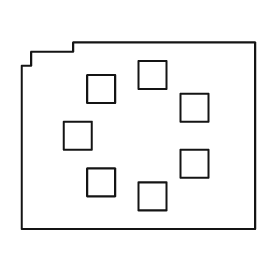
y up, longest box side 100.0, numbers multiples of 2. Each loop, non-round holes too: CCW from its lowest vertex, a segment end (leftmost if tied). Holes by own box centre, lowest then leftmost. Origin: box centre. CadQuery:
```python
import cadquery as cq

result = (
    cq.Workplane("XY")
    .moveTo(-50.0, -40.0)
    .lineTo(50.0, -40.0)
    .lineTo(50.0, 40.0)
    .lineTo(-28.0, 40.0)
    .lineTo(-28.0, 36.0)
    .lineTo(-46.0, 36.0)
    .lineTo(-46.0, 30.0)
    .lineTo(-50.0, 30.0)
    .close()
    .moveTo(0.0, -32.0)
    .lineTo(12.0, -32.0)
    .lineTo(12.0, -20.0)
    .lineTo(0.0, -20.0)
    .close()
    .moveTo(-22.0, -26.0)
    .lineTo(-10.0, -26.0)
    .lineTo(-10.0, -14.0)
    .lineTo(-22.0, -14.0)
    .close()
    .moveTo(18.0, -18.0)
    .lineTo(30.0, -18.0)
    .lineTo(30.0, -6.0)
    .lineTo(18.0, -6.0)
    .close()
    .moveTo(-32.0, -6.0)
    .lineTo(-20.0, -6.0)
    .lineTo(-20.0, 6.0)
    .lineTo(-32.0, 6.0)
    .close()
    .moveTo(18.0, 6.0)
    .lineTo(30.0, 6.0)
    .lineTo(30.0, 18.0)
    .lineTo(18.0, 18.0)
    .close()
    .moveTo(-22.0, 14.0)
    .lineTo(-10.0, 14.0)
    .lineTo(-10.0, 26.0)
    .lineTo(-22.0, 26.0)
    .close()
    .moveTo(0.0, 20.0)
    .lineTo(12.0, 20.0)
    .lineTo(12.0, 32.0)
    .lineTo(0.0, 32.0)
    .close()
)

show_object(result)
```